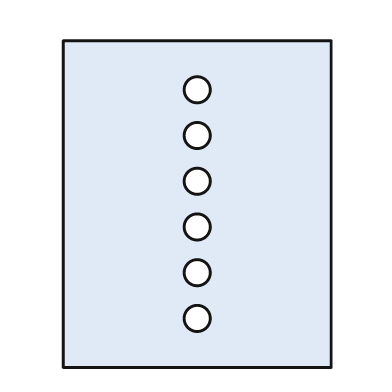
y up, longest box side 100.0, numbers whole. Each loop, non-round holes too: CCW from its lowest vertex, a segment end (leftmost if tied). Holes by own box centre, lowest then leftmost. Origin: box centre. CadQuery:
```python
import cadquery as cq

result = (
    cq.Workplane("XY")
    .moveTo(-41.0, -50.0)
    .lineTo(41.0, -50.0)
    .lineTo(41.0, 50.0)
    .lineTo(-41.0, 50.0)
    .close()
    .moveTo(0.0, -35.0)
    .circle(4.0)
    .moveTo(0.0, -21.0)
    .circle(4.0)
    .moveTo(0.0, -7.0)
    .circle(4.0)
    .moveTo(0.0, 7.0)
    .circle(4.0)
    .moveTo(0.0, 21.0)
    .circle(4.0)
    .moveTo(0.0, 35.0)
    .circle(4.0)
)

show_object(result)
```